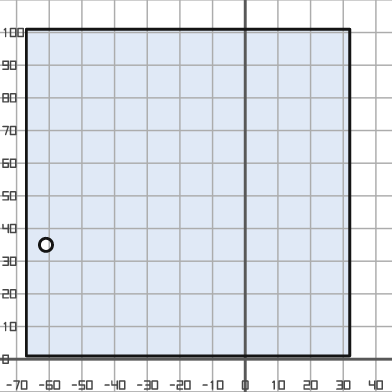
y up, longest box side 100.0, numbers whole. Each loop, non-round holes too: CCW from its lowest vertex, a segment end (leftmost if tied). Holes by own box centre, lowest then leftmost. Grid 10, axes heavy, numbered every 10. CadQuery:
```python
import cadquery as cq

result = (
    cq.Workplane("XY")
    .moveTo(-67.0, 1.0)
    .lineTo(32.0, 1.0)
    .lineTo(32.0, 101.0)
    .lineTo(-67.0, 101.0)
    .close()
    .moveTo(-61.0, 35.0)
    .circle(2.0)
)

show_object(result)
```